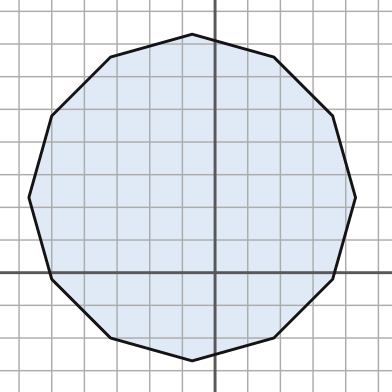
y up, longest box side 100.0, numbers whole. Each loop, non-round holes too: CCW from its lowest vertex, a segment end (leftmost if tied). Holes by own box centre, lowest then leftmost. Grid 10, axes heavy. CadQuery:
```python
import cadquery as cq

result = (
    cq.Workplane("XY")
    .moveTo(-7.0, -27.0)
    .lineTo(18.0, -20.0)
    .lineTo(36.0, -2.0)
    .lineTo(43.0, 23.0)
    .lineTo(36.0, 48.0)
    .lineTo(18.0, 66.0)
    .lineTo(-7.0, 73.0)
    .lineTo(-32.0, 66.0)
    .lineTo(-50.0, 48.0)
    .lineTo(-57.0, 23.0)
    .lineTo(-50.0, -2.0)
    .lineTo(-32.0, -20.0)
    .close()
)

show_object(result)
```